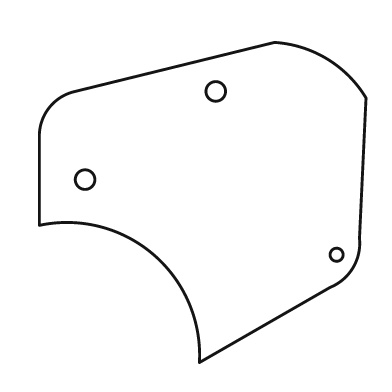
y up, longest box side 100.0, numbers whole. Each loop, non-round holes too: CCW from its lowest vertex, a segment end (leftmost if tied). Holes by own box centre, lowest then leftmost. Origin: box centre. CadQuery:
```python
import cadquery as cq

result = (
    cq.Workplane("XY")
    .moveTo(-1.0, -49.0)
    .lineTo(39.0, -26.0)
    .threePointArc((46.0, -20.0), (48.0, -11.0))
    .lineTo(50.0, 32.0)
    .threePointArc((38.0, 44.0), (22.0, 49.0))
    .lineTo(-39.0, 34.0)
    .threePointArc((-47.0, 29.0), (-50.0, 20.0))
    .lineTo(-50.0, -7.0)
    .threePointArc((-15.0, -16.0), (-1.0, -49.0))
    .close()
    .moveTo(41.0, -16.0)
    .circle(2.0)
    .moveTo(-36.0, 7.0)
    .circle(3.0)
    .moveTo(4.0, 34.0)
    .circle(3.0)
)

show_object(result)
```